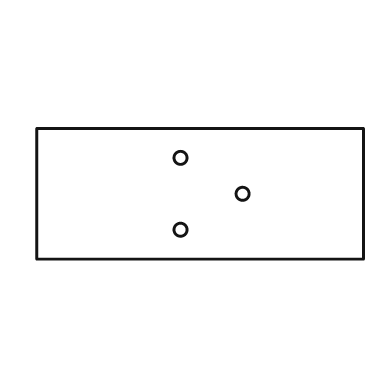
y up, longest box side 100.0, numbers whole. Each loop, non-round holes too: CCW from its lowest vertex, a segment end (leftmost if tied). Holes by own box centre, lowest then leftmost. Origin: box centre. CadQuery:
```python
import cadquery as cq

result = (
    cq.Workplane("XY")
    .moveTo(-50.0, -20.0)
    .lineTo(50.0, -20.0)
    .lineTo(50.0, 20.0)
    .lineTo(-50.0, 20.0)
    .close()
    .moveTo(-6.0, -11.0)
    .circle(2.0)
    .moveTo(13.0, 0.0)
    .circle(2.0)
    .moveTo(-6.0, 11.0)
    .circle(2.0)
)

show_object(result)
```